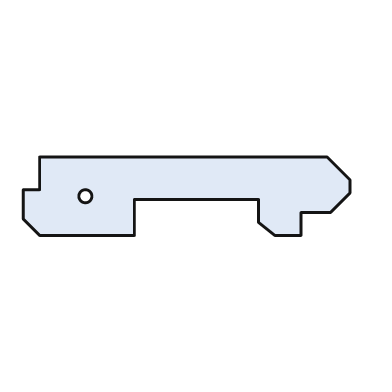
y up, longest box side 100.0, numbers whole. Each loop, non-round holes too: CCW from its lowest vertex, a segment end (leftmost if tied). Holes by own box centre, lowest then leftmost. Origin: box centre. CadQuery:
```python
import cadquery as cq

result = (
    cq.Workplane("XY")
    .moveTo(-45.0, -12.0)
    .lineTo(-16.0, -12.0)
    .lineTo(-16.0, -1.0)
    .lineTo(22.0, -1.0)
    .lineTo(22.0, -8.0)
    .lineTo(27.0, -12.0)
    .lineTo(35.0, -12.0)
    .lineTo(35.0, -5.0)
    .lineTo(44.0, -5.0)
    .lineTo(50.0, 1.0)
    .lineTo(50.0, 5.0)
    .lineTo(43.0, 12.0)
    .lineTo(-45.0, 12.0)
    .lineTo(-45.0, 2.0)
    .lineTo(-50.0, 2.0)
    .lineTo(-50.0, -7.0)
    .close()
    .moveTo(-31.0, 0.0)
    .circle(2.0)
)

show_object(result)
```